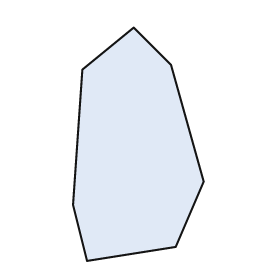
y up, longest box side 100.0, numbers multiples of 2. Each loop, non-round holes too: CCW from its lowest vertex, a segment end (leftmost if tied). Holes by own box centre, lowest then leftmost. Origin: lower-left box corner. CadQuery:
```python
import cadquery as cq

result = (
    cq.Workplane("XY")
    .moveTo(6.0, 0.0)
    .lineTo(44.0, 6.0)
    .lineTo(56.0, 34.0)
    .lineTo(42.0, 84.0)
    .lineTo(26.0, 100.0)
    .lineTo(4.0, 82.0)
    .lineTo(0.0, 24.0)
    .close()
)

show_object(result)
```